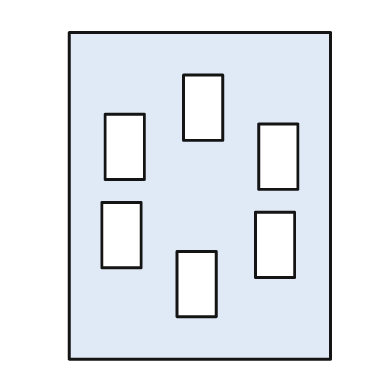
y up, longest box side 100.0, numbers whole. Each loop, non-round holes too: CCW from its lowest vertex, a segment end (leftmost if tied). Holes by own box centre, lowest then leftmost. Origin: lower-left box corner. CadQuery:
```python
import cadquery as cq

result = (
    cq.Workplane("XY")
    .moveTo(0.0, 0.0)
    .lineTo(80.0, 0.0)
    .lineTo(80.0, 100.0)
    .lineTo(0.0, 100.0)
    .close()
    .moveTo(33.0, 13.0)
    .lineTo(45.0, 13.0)
    .lineTo(45.0, 33.0)
    .lineTo(33.0, 33.0)
    .close()
    .moveTo(57.0, 25.0)
    .lineTo(69.0, 25.0)
    .lineTo(69.0, 45.0)
    .lineTo(57.0, 45.0)
    .close()
    .moveTo(10.0, 28.0)
    .lineTo(22.0, 28.0)
    .lineTo(22.0, 48.0)
    .lineTo(10.0, 48.0)
    .close()
    .moveTo(58.0, 52.0)
    .lineTo(70.0, 52.0)
    .lineTo(70.0, 72.0)
    .lineTo(58.0, 72.0)
    .close()
    .moveTo(11.0, 55.0)
    .lineTo(23.0, 55.0)
    .lineTo(23.0, 75.0)
    .lineTo(11.0, 75.0)
    .close()
    .moveTo(35.0, 67.0)
    .lineTo(47.0, 67.0)
    .lineTo(47.0, 87.0)
    .lineTo(35.0, 87.0)
    .close()
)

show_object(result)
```